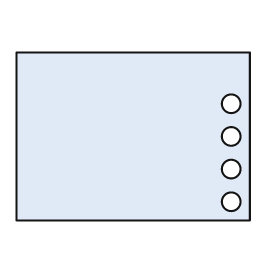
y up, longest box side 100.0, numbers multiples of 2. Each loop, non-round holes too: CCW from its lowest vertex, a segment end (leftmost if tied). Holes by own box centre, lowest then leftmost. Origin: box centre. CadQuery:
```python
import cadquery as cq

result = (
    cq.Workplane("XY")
    .moveTo(-50.0, -36.0)
    .lineTo(50.0, -36.0)
    .lineTo(50.0, 36.0)
    .lineTo(-50.0, 36.0)
    .close()
    .moveTo(42.0, -28.0)
    .circle(4.0)
    .moveTo(42.0, -14.0)
    .circle(4.0)
    .moveTo(42.0, 0.0)
    .circle(4.0)
    .moveTo(42.0, 14.0)
    .circle(4.0)
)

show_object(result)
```